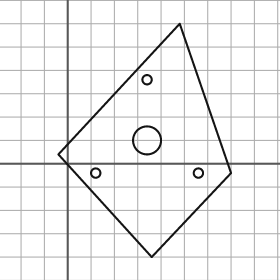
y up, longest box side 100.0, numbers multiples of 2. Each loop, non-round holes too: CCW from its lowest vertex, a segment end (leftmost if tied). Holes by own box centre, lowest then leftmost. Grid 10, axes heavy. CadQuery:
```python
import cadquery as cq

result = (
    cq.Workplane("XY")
    .moveTo(36.0, -40.0)
    .lineTo(70.0, -4.0)
    .lineTo(48.0, 60.0)
    .lineTo(-4.0, 4.0)
    .close()
    .moveTo(12.0, -4.0)
    .circle(2.0)
    .moveTo(56.0, -4.0)
    .circle(2.0)
    .moveTo(34.0, 10.0)
    .circle(6.0)
    .moveTo(34.0, 36.0)
    .circle(2.0)
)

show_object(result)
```